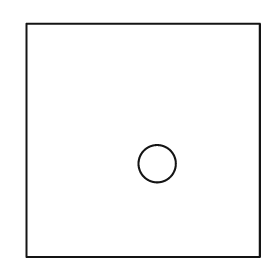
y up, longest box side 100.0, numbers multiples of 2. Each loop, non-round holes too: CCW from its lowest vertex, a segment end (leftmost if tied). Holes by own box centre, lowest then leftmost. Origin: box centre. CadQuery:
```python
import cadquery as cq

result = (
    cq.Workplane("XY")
    .moveTo(-50.0, -50.0)
    .lineTo(50.0, -50.0)
    .lineTo(50.0, 50.0)
    .lineTo(-50.0, 50.0)
    .close()
    .moveTo(6.0, -10.0)
    .circle(8.0)
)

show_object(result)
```